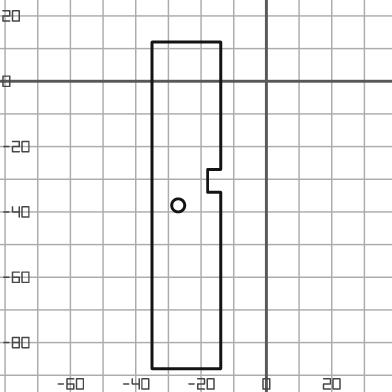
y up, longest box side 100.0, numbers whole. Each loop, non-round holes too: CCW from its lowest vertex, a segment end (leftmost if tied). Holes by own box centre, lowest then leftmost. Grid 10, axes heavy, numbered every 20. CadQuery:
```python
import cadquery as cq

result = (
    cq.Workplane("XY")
    .moveTo(-35.0, -88.0)
    .lineTo(-14.0, -88.0)
    .lineTo(-14.0, -34.0)
    .lineTo(-18.0, -34.0)
    .lineTo(-18.0, -27.0)
    .lineTo(-14.0, -27.0)
    .lineTo(-14.0, 12.0)
    .lineTo(-35.0, 12.0)
    .close()
    .moveTo(-27.0, -38.0)
    .circle(2.0)
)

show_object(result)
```